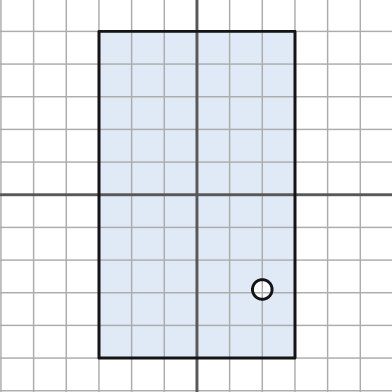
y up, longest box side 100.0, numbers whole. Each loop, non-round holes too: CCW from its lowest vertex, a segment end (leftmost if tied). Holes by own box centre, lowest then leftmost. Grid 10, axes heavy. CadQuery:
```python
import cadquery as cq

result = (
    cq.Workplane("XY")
    .moveTo(-30.0, -50.0)
    .lineTo(30.0, -50.0)
    .lineTo(30.0, 50.0)
    .lineTo(-30.0, 50.0)
    .close()
    .moveTo(20.0, -29.0)
    .circle(3.0)
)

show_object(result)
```